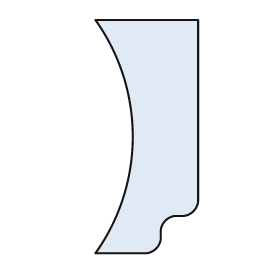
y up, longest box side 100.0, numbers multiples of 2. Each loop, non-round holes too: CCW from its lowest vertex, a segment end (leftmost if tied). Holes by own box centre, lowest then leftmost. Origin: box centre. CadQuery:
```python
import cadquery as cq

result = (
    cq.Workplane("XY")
    .moveTo(-22.0, -50.0)
    .lineTo(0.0, -50.0)
    .threePointArc((4.0, -48.0), (6.0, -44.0))
    .lineTo(6.0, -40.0)
    .threePointArc((8.0, -36.0), (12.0, -34.0))
    .lineTo(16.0, -34.0)
    .threePointArc((20.0, -32.0), (22.0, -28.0))
    .lineTo(22.0, 50.0)
    .lineTo(-22.0, 50.0)
    .threePointArc((-6.0, 0.0), (-22.0, -50.0))
    .close()
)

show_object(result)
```